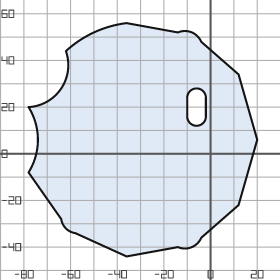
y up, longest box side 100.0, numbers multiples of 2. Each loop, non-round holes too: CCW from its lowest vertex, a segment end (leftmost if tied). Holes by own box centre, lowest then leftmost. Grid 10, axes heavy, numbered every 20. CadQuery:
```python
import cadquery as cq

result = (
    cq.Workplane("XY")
    .moveTo(-36.0, -44.0)
    .lineTo(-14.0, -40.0)
    .threePointArc((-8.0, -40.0), (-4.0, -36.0))
    .lineTo(12.0, -22.0)
    .lineTo(20.0, 6.0)
    .lineTo(12.0, 34.0)
    .lineTo(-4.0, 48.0)
    .threePointArc((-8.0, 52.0), (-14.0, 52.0))
    .lineTo(-36.0, 56.0)
    .threePointArc((-50.0, 52.0), (-62.0, 44.0))
    .threePointArc((-64.0, 28.0), (-78.0, 20.0))
    .threePointArc((-74.0, 6.0), (-78.0, -8.0))
    .lineTo(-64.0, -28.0)
    .threePointArc((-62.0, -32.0), (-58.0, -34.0))
    .close()
    .moveTo(-10.0, 16.0)
    .threePointArc((-6.0, 12.0), (-2.0, 16.0))
    .lineTo(-2.0, 24.0)
    .threePointArc((-6.0, 28.0), (-10.0, 24.0))
    .close()
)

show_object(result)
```